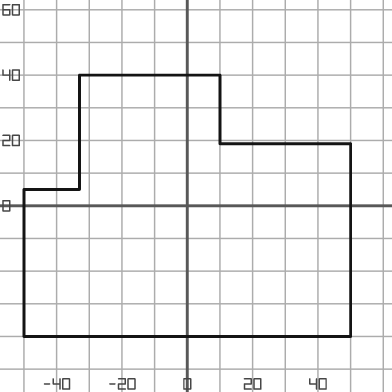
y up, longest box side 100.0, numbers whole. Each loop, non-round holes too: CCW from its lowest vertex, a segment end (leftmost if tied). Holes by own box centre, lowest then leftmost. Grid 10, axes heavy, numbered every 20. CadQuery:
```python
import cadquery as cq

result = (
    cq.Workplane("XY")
    .moveTo(-50.0, -40.0)
    .lineTo(50.0, -40.0)
    .lineTo(50.0, 19.0)
    .lineTo(10.0, 19.0)
    .lineTo(10.0, 40.0)
    .lineTo(-33.0, 40.0)
    .lineTo(-33.0, 5.0)
    .lineTo(-50.0, 5.0)
    .close()
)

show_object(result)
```